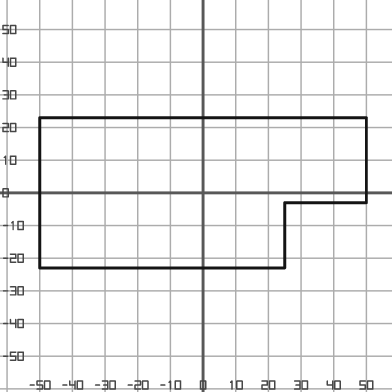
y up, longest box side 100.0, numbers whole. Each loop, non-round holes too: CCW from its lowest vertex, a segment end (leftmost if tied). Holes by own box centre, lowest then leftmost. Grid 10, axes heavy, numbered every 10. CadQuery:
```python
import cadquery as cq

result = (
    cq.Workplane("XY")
    .moveTo(-50.0, -23.0)
    .lineTo(25.0, -23.0)
    .lineTo(25.0, -3.0)
    .lineTo(50.0, -3.0)
    .lineTo(50.0, 23.0)
    .lineTo(-50.0, 23.0)
    .close()
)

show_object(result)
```